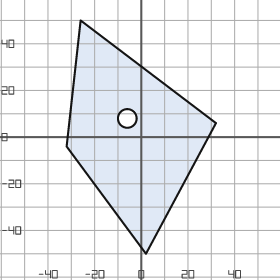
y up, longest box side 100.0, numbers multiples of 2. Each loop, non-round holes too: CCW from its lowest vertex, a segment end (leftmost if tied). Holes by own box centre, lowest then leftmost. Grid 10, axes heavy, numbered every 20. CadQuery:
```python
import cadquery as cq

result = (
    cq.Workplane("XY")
    .moveTo(2.0, -50.0)
    .lineTo(32.0, 6.0)
    .lineTo(-26.0, 50.0)
    .lineTo(-32.0, -4.0)
    .close()
    .moveTo(-6.0, 8.0)
    .circle(4.0)
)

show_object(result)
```